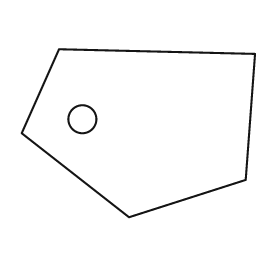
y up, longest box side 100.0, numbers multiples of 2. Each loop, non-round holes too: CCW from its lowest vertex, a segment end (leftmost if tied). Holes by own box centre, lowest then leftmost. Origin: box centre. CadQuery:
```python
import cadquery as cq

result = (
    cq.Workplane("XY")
    .moveTo(-4.0, -36.0)
    .lineTo(46.0, -20.0)
    .lineTo(50.0, 34.0)
    .lineTo(-34.0, 36.0)
    .lineTo(-50.0, 0.0)
    .close()
    .moveTo(-24.0, 6.0)
    .circle(6.0)
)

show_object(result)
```